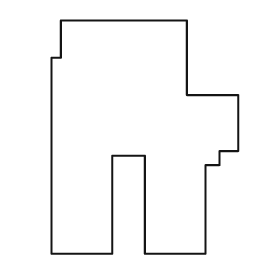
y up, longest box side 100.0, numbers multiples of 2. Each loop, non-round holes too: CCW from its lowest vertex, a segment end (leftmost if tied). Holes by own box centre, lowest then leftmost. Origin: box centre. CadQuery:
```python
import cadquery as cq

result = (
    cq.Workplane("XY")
    .moveTo(-40.0, -50.0)
    .lineTo(-14.0, -50.0)
    .lineTo(-14.0, -8.0)
    .lineTo(0.0, -8.0)
    .lineTo(0.0, -50.0)
    .lineTo(26.0, -50.0)
    .lineTo(26.0, -12.0)
    .lineTo(32.0, -12.0)
    .lineTo(32.0, -6.0)
    .lineTo(40.0, -6.0)
    .lineTo(40.0, 18.0)
    .lineTo(18.0, 18.0)
    .lineTo(18.0, 50.0)
    .lineTo(-36.0, 50.0)
    .lineTo(-36.0, 34.0)
    .lineTo(-40.0, 34.0)
    .close()
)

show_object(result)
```